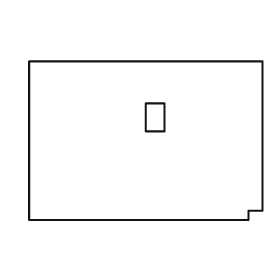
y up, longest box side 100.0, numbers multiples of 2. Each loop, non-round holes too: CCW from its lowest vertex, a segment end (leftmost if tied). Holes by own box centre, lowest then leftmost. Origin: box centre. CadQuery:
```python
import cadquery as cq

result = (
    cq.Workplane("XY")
    .moveTo(-50.0, -34.0)
    .lineTo(44.0, -34.0)
    .lineTo(44.0, -30.0)
    .lineTo(50.0, -30.0)
    .lineTo(50.0, 34.0)
    .lineTo(-50.0, 34.0)
    .close()
    .moveTo(0.0, 4.0)
    .lineTo(8.0, 4.0)
    .lineTo(8.0, 16.0)
    .lineTo(0.0, 16.0)
    .close()
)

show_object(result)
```